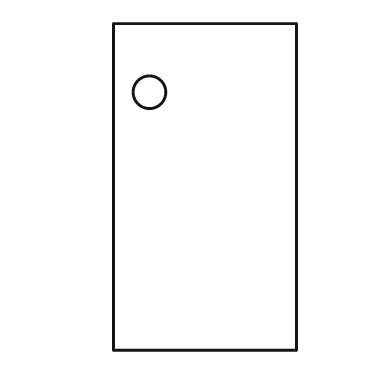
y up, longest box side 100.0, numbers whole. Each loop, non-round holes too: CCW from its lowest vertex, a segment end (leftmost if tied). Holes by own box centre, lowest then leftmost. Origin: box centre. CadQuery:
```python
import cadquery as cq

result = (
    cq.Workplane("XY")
    .moveTo(-28.0, -50.0)
    .lineTo(28.0, -50.0)
    .lineTo(28.0, 50.0)
    .lineTo(-28.0, 50.0)
    .close()
    .moveTo(-17.0, 29.0)
    .circle(5.0)
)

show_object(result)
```